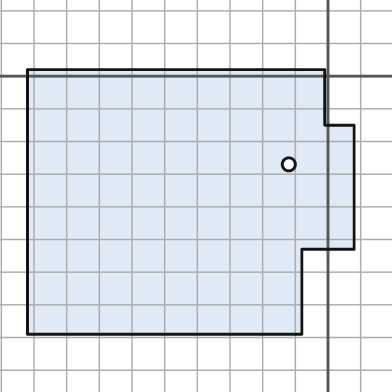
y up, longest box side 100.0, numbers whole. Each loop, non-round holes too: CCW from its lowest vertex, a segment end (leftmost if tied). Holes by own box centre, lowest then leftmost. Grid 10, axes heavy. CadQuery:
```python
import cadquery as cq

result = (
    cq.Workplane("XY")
    .moveTo(-92.0, -79.0)
    .lineTo(-8.0, -79.0)
    .lineTo(-8.0, -53.0)
    .lineTo(8.0, -53.0)
    .lineTo(8.0, -15.0)
    .lineTo(-1.0, -15.0)
    .lineTo(-1.0, 2.0)
    .lineTo(-92.0, 2.0)
    .close()
    .moveTo(-12.0, -27.0)
    .circle(2.0)
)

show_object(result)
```